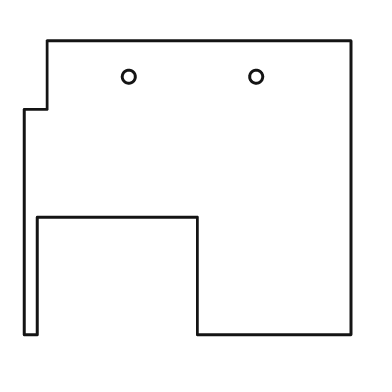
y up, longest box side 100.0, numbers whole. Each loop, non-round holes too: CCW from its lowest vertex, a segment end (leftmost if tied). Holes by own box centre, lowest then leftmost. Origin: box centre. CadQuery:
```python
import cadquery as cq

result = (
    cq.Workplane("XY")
    .moveTo(-50.0, -45.0)
    .lineTo(-46.0, -45.0)
    .lineTo(-46.0, -9.0)
    .lineTo(3.0, -9.0)
    .lineTo(3.0, -45.0)
    .lineTo(50.0, -45.0)
    .lineTo(50.0, 45.0)
    .lineTo(-43.0, 45.0)
    .lineTo(-43.0, 24.0)
    .lineTo(-50.0, 24.0)
    .close()
    .moveTo(-18.0, 34.0)
    .circle(2.0)
    .moveTo(21.0, 34.0)
    .circle(2.0)
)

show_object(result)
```